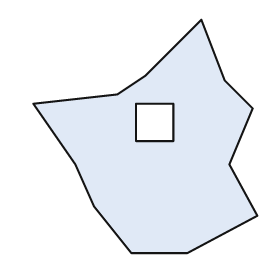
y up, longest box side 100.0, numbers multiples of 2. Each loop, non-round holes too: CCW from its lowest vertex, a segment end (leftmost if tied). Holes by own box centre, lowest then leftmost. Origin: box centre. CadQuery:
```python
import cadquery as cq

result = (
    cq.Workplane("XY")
    .moveTo(-6.0, -50.0)
    .lineTo(18.0, -50.0)
    .lineTo(48.0, -34.0)
    .lineTo(36.0, -12.0)
    .lineTo(46.0, 12.0)
    .lineTo(34.0, 24.0)
    .lineTo(24.0, 50.0)
    .lineTo(0.0, 26.0)
    .lineTo(-12.0, 18.0)
    .lineTo(-48.0, 14.0)
    .lineTo(-30.0, -12.0)
    .lineTo(-22.0, -30.0)
    .close()
    .moveTo(-4.0, -2.0)
    .lineTo(12.0, -2.0)
    .lineTo(12.0, 14.0)
    .lineTo(-4.0, 14.0)
    .close()
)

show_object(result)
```